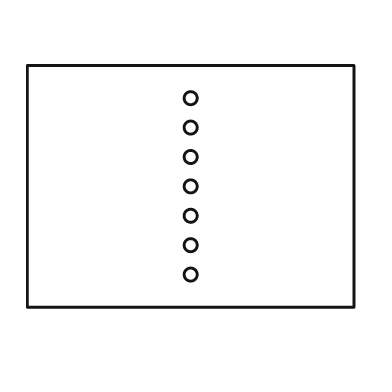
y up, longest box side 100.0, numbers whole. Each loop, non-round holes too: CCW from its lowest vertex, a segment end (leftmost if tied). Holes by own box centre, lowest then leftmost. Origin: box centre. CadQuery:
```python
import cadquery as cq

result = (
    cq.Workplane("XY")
    .moveTo(-50.0, -37.0)
    .lineTo(50.0, -37.0)
    .lineTo(50.0, 37.0)
    .lineTo(-50.0, 37.0)
    .close()
    .moveTo(0.0, -27.0)
    .circle(2.0)
    .moveTo(0.0, -18.0)
    .circle(2.0)
    .moveTo(0.0, -9.0)
    .circle(2.0)
    .moveTo(0.0, 0.0)
    .circle(2.0)
    .moveTo(0.0, 9.0)
    .circle(2.0)
    .moveTo(0.0, 18.0)
    .circle(2.0)
    .moveTo(0.0, 27.0)
    .circle(2.0)
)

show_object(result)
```